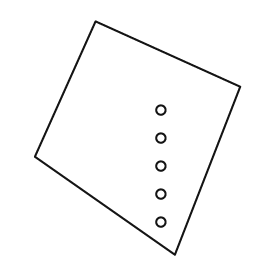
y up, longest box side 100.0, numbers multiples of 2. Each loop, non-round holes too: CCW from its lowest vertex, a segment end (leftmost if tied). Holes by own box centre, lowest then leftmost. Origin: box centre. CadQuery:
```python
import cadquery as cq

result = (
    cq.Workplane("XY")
    .moveTo(16.0, -50.0)
    .lineTo(44.0, 22.0)
    .lineTo(-18.0, 50.0)
    .lineTo(-44.0, -8.0)
    .close()
    .moveTo(10.0, -36.0)
    .circle(2.0)
    .moveTo(10.0, -24.0)
    .circle(2.0)
    .moveTo(10.0, -12.0)
    .circle(2.0)
    .moveTo(10.0, 0.0)
    .circle(2.0)
    .moveTo(10.0, 12.0)
    .circle(2.0)
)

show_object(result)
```